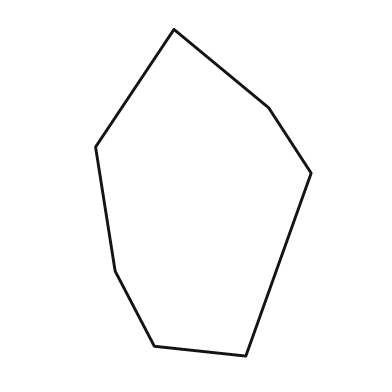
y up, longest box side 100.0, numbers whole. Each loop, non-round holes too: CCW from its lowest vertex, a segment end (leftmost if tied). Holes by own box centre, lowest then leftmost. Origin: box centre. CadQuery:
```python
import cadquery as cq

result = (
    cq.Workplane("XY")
    .moveTo(13.0, -50.0)
    .lineTo(33.0, 6.0)
    .lineTo(20.0, 26.0)
    .lineTo(-9.0, 50.0)
    .lineTo(-33.0, 14.0)
    .lineTo(-27.0, -24.0)
    .lineTo(-15.0, -47.0)
    .close()
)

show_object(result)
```